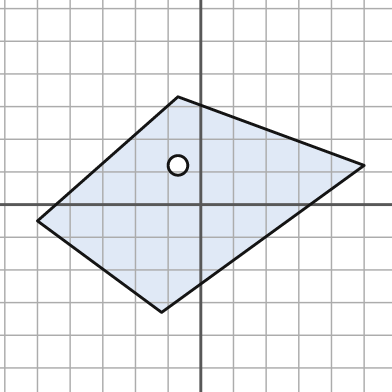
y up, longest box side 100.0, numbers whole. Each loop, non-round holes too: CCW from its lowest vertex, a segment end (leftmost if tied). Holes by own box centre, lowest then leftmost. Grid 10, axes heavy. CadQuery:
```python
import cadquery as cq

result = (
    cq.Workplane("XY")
    .moveTo(-12.0, -33.0)
    .lineTo(50.0, 12.0)
    .lineTo(-7.0, 33.0)
    .lineTo(-50.0, -5.0)
    .close()
    .moveTo(-7.0, 12.0)
    .circle(3.0)
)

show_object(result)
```